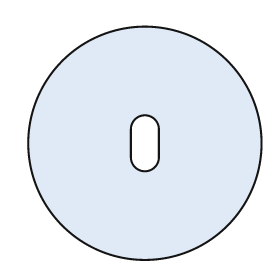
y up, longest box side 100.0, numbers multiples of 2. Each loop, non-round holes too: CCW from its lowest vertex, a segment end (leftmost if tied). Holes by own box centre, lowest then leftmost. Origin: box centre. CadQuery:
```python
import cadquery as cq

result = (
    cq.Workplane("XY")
    .moveTo(0.0, 0.0)
    .circle(50.0)
    .moveTo(-6.0, -6.0)
    .threePointArc((0.0, -12.0), (6.0, -6.0))
    .lineTo(6.0, 6.0)
    .threePointArc((0.0, 12.0), (-6.0, 6.0))
    .close()
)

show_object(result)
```